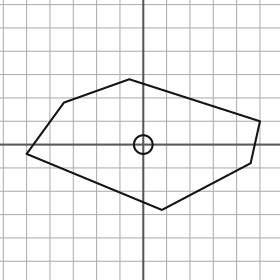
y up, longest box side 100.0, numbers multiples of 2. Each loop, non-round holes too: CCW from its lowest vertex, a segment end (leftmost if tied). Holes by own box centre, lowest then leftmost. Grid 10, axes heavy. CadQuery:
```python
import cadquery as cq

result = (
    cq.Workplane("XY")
    .moveTo(8.0, -28.0)
    .lineTo(46.0, -8.0)
    .lineTo(50.0, 10.0)
    .lineTo(-6.0, 28.0)
    .lineTo(-34.0, 18.0)
    .lineTo(-50.0, -4.0)
    .close()
    .moveTo(0.0, 0.0)
    .circle(4.0)
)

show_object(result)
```